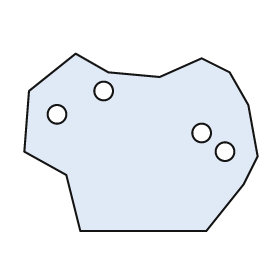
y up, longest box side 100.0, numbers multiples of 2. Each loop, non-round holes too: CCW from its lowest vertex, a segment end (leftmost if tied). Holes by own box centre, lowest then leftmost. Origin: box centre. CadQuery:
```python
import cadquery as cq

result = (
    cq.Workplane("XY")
    .moveTo(-26.0, -38.0)
    .lineTo(28.0, -38.0)
    .lineTo(44.0, -18.0)
    .lineTo(50.0, -6.0)
    .lineTo(46.0, 16.0)
    .lineTo(38.0, 30.0)
    .lineTo(26.0, 36.0)
    .lineTo(8.0, 28.0)
    .lineTo(-14.0, 30.0)
    .lineTo(-28.0, 38.0)
    .lineTo(-48.0, 22.0)
    .lineTo(-50.0, -4.0)
    .lineTo(-32.0, -14.0)
    .close()
    .moveTo(36.0, -4.0)
    .circle(4.0)
    .moveTo(26.0, 4.0)
    .circle(4.0)
    .moveTo(-36.0, 12.0)
    .circle(4.0)
    .moveTo(-16.0, 22.0)
    .circle(4.0)
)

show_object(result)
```